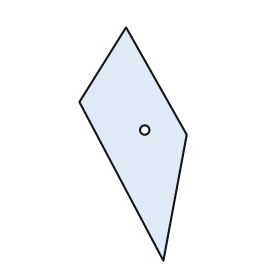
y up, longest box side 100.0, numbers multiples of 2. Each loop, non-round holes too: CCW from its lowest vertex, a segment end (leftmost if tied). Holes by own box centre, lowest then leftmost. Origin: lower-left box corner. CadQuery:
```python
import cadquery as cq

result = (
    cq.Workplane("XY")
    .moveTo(36.0, 0.0)
    .lineTo(46.0, 54.0)
    .lineTo(20.0, 100.0)
    .lineTo(0.0, 68.0)
    .close()
    .moveTo(28.0, 56.0)
    .circle(2.0)
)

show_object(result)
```